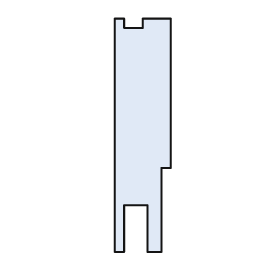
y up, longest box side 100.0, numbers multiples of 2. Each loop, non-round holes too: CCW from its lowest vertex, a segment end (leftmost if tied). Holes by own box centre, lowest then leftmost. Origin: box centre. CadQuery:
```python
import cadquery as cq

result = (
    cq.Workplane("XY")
    .moveTo(-12.0, -50.0)
    .lineTo(-8.0, -50.0)
    .lineTo(-8.0, -30.0)
    .lineTo(2.0, -30.0)
    .lineTo(2.0, -50.0)
    .lineTo(8.0, -50.0)
    .lineTo(8.0, -14.0)
    .lineTo(12.0, -14.0)
    .lineTo(12.0, 50.0)
    .lineTo(0.0, 50.0)
    .lineTo(0.0, 46.0)
    .lineTo(-8.0, 46.0)
    .lineTo(-8.0, 50.0)
    .lineTo(-12.0, 50.0)
    .close()
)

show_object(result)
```